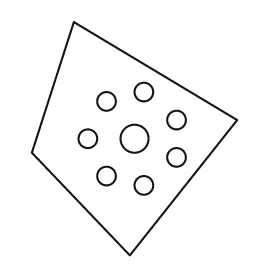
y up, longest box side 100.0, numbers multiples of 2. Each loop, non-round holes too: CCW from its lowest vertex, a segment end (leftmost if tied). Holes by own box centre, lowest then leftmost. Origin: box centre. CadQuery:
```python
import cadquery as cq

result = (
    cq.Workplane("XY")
    .moveTo(-2.0, -50.0)
    .lineTo(44.0, 8.0)
    .lineTo(-26.0, 50.0)
    .lineTo(-44.0, -6.0)
    .close()
    .moveTo(4.0, -20.0)
    .circle(4.0)
    .moveTo(-12.0, -16.0)
    .circle(4.0)
    .moveTo(18.0, -8.0)
    .circle(4.0)
    .moveTo(-20.0, 0.0)
    .circle(4.0)
    .moveTo(0.0, 0.0)
    .circle(6.0)
    .moveTo(18.0, 8.0)
    .circle(4.0)
    .moveTo(-12.0, 16.0)
    .circle(4.0)
    .moveTo(4.0, 20.0)
    .circle(4.0)
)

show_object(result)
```